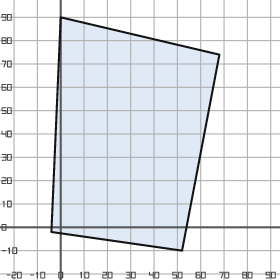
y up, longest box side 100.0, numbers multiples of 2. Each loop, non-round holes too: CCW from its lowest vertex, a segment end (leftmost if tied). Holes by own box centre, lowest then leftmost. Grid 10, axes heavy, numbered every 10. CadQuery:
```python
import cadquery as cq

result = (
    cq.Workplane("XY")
    .moveTo(52.0, -10.0)
    .lineTo(68.0, 74.0)
    .lineTo(0.0, 90.0)
    .lineTo(-4.0, -2.0)
    .close()
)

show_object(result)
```